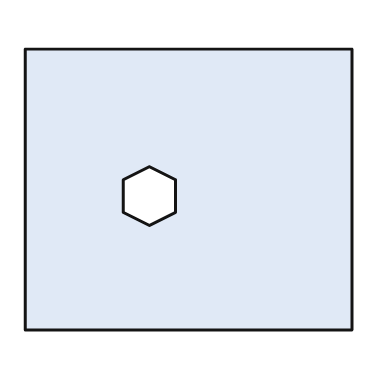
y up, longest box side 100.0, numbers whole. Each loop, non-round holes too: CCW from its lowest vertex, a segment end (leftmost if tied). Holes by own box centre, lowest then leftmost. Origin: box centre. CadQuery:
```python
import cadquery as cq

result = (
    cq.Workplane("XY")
    .moveTo(-50.0, -43.0)
    .lineTo(50.0, -43.0)
    .lineTo(50.0, 43.0)
    .lineTo(-50.0, 43.0)
    .close()
    .moveTo(-12.0, -11.0)
    .lineTo(-4.0, -7.0)
    .lineTo(-4.0, 3.0)
    .lineTo(-12.0, 7.0)
    .lineTo(-20.0, 3.0)
    .lineTo(-20.0, -7.0)
    .close()
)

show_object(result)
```